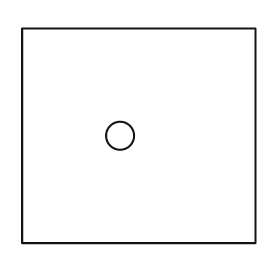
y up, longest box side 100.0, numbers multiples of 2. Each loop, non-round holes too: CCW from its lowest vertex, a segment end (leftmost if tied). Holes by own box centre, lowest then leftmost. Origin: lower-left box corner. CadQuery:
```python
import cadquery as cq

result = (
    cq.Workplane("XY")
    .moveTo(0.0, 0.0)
    .lineTo(100.0, 0.0)
    .lineTo(100.0, 92.0)
    .lineTo(0.0, 92.0)
    .close()
    .moveTo(42.0, 46.0)
    .circle(6.0)
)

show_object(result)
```